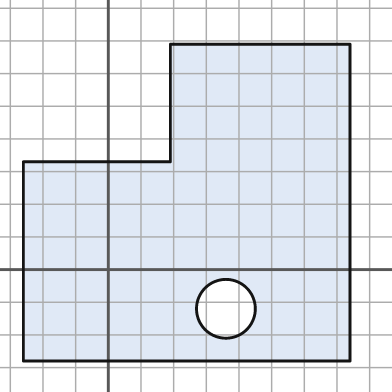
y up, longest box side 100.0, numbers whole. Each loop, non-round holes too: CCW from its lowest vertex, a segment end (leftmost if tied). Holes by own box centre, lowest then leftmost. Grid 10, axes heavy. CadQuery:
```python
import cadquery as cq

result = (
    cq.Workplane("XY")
    .moveTo(-26.0, -28.0)
    .lineTo(74.0, -28.0)
    .lineTo(74.0, 69.0)
    .lineTo(19.0, 69.0)
    .lineTo(19.0, 33.0)
    .lineTo(-26.0, 33.0)
    .close()
    .moveTo(36.0, -12.0)
    .circle(9.0)
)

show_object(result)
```